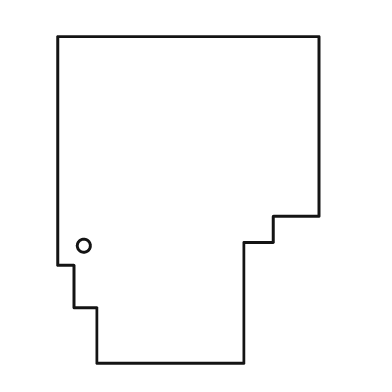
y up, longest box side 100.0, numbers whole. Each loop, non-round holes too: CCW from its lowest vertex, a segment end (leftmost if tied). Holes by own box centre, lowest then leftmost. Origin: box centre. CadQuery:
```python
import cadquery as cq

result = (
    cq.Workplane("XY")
    .moveTo(-28.0, -50.0)
    .lineTo(17.0, -50.0)
    .lineTo(17.0, -13.0)
    .lineTo(26.0, -13.0)
    .lineTo(26.0, -5.0)
    .lineTo(40.0, -5.0)
    .lineTo(40.0, 50.0)
    .lineTo(-40.0, 50.0)
    .lineTo(-40.0, -20.0)
    .lineTo(-35.0, -20.0)
    .lineTo(-35.0, -33.0)
    .lineTo(-28.0, -33.0)
    .close()
    .moveTo(-32.0, -14.0)
    .circle(2.0)
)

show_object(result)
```